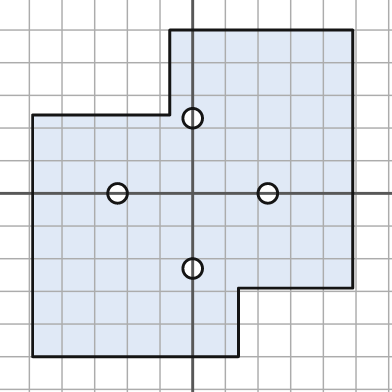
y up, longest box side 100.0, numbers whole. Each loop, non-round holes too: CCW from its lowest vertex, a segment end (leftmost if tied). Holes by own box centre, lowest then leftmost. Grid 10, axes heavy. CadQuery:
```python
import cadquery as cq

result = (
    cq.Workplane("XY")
    .moveTo(-49.0, -50.0)
    .lineTo(14.0, -50.0)
    .lineTo(14.0, -29.0)
    .lineTo(49.0, -29.0)
    .lineTo(49.0, 50.0)
    .lineTo(-7.0, 50.0)
    .lineTo(-7.0, 24.0)
    .lineTo(-49.0, 24.0)
    .close()
    .moveTo(0.0, -23.0)
    .circle(3.0)
    .moveTo(-23.0, 0.0)
    .circle(3.0)
    .moveTo(23.0, 0.0)
    .circle(3.0)
    .moveTo(0.0, 23.0)
    .circle(3.0)
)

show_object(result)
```